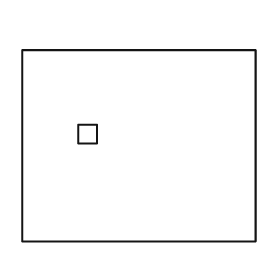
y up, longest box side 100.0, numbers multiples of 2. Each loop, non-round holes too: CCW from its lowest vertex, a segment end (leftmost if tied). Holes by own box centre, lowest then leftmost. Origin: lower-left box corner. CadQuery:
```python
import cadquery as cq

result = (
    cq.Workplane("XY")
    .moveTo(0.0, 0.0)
    .lineTo(100.0, 0.0)
    .lineTo(100.0, 82.0)
    .lineTo(0.0, 82.0)
    .close()
    .moveTo(24.0, 42.0)
    .lineTo(32.0, 42.0)
    .lineTo(32.0, 50.0)
    .lineTo(24.0, 50.0)
    .close()
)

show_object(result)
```